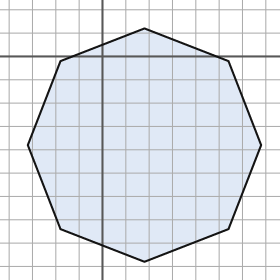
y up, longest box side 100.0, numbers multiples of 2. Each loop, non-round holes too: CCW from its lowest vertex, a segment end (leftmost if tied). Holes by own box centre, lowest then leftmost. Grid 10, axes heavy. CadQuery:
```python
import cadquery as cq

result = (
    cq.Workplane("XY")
    .moveTo(18.0, -88.0)
    .lineTo(54.0, -74.0)
    .lineTo(68.0, -38.0)
    .lineTo(54.0, -2.0)
    .lineTo(18.0, 12.0)
    .lineTo(-18.0, -2.0)
    .lineTo(-32.0, -38.0)
    .lineTo(-18.0, -74.0)
    .close()
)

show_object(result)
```